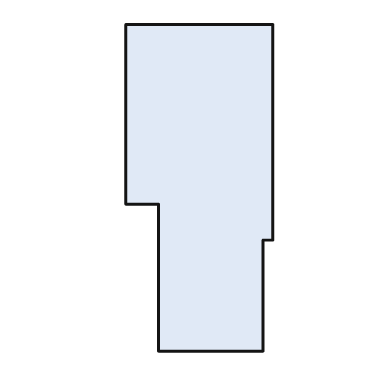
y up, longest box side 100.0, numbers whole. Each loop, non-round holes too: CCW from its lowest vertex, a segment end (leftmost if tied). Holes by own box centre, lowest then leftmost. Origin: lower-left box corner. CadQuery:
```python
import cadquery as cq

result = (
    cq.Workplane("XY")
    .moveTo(10.0, 0.0)
    .lineTo(42.0, 0.0)
    .lineTo(42.0, 34.0)
    .lineTo(45.0, 34.0)
    .lineTo(45.0, 100.0)
    .lineTo(0.0, 100.0)
    .lineTo(0.0, 45.0)
    .lineTo(10.0, 45.0)
    .close()
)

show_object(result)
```